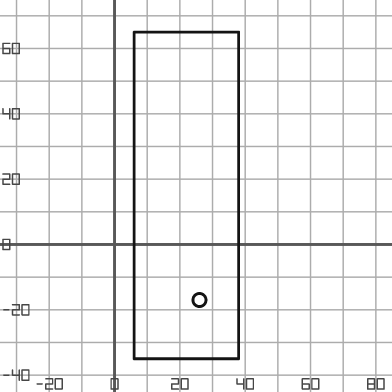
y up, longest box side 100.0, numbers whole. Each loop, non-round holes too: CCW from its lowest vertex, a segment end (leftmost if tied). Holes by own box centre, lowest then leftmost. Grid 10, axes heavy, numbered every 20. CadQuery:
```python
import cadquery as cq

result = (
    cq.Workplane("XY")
    .moveTo(6.0, -35.0)
    .lineTo(38.0, -35.0)
    .lineTo(38.0, 65.0)
    .lineTo(6.0, 65.0)
    .close()
    .moveTo(26.0, -17.0)
    .circle(2.0)
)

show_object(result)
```